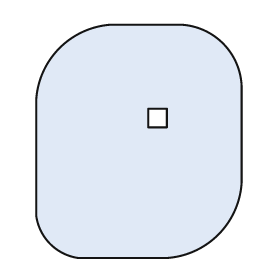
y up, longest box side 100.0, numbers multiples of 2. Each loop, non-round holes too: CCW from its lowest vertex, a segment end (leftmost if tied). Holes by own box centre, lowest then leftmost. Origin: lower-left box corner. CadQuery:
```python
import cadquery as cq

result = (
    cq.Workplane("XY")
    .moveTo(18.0, 0.0)
    .lineTo(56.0, 0.0)
    .threePointArc((78.0, 10.0), (88.0, 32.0))
    .lineTo(88.0, 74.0)
    .threePointArc((80.0, 92.0), (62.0, 100.0))
    .lineTo(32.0, 100.0)
    .threePointArc((10.0, 90.0), (0.0, 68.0))
    .lineTo(0.0, 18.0)
    .threePointArc((6.0, 6.0), (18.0, 0.0))
    .close()
    .moveTo(48.0, 56.0)
    .lineTo(56.0, 56.0)
    .lineTo(56.0, 64.0)
    .lineTo(48.0, 64.0)
    .close()
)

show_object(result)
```